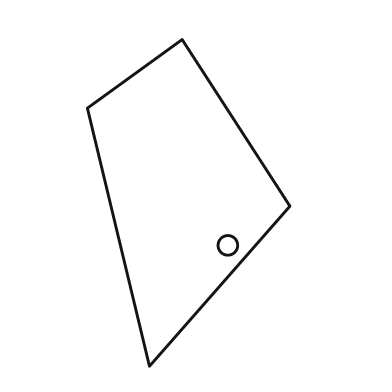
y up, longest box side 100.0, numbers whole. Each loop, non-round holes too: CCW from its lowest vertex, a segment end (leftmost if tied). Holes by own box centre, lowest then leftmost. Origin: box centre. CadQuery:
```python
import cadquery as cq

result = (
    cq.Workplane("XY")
    .moveTo(-12.0, -50.0)
    .lineTo(31.0, -1.0)
    .lineTo(-2.0, 50.0)
    .lineTo(-31.0, 29.0)
    .close()
    .moveTo(12.0, -13.0)
    .circle(3.0)
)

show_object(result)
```